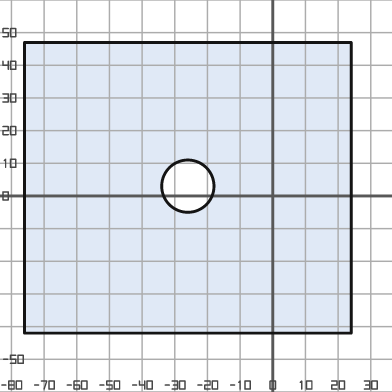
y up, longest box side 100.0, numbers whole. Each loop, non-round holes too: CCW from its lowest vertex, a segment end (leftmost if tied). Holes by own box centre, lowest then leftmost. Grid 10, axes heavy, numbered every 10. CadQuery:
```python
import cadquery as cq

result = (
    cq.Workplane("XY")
    .moveTo(-76.0, -42.0)
    .lineTo(24.0, -42.0)
    .lineTo(24.0, 47.0)
    .lineTo(-76.0, 47.0)
    .close()
    .moveTo(-26.0, 3.0)
    .circle(8.0)
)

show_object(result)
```